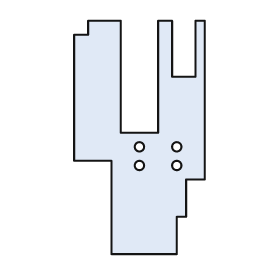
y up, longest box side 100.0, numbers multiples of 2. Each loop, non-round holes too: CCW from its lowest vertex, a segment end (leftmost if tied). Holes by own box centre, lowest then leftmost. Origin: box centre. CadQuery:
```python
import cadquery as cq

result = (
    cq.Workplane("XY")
    .moveTo(-12.0, -50.0)
    .lineTo(16.0, -50.0)
    .lineTo(16.0, -34.0)
    .lineTo(20.0, -34.0)
    .lineTo(20.0, -18.0)
    .lineTo(28.0, -18.0)
    .lineTo(28.0, 50.0)
    .lineTo(24.0, 50.0)
    .lineTo(24.0, 26.0)
    .lineTo(14.0, 26.0)
    .lineTo(14.0, 50.0)
    .lineTo(8.0, 50.0)
    .lineTo(8.0, 2.0)
    .lineTo(-8.0, 2.0)
    .lineTo(-8.0, 50.0)
    .lineTo(-22.0, 50.0)
    .lineTo(-22.0, 44.0)
    .lineTo(-28.0, 44.0)
    .lineTo(-28.0, -10.0)
    .lineTo(-12.0, -10.0)
    .close()
    .moveTo(0.0, -12.0)
    .circle(2.0)
    .moveTo(16.0, -12.0)
    .circle(2.0)
    .moveTo(0.0, -4.0)
    .circle(2.0)
    .moveTo(16.0, -4.0)
    .circle(2.0)
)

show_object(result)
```